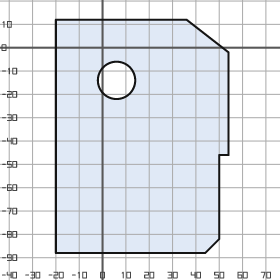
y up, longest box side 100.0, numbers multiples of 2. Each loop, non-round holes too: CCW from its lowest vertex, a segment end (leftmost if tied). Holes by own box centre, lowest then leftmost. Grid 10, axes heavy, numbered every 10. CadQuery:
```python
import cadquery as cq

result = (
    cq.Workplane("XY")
    .moveTo(-20.0, -88.0)
    .lineTo(44.0, -88.0)
    .lineTo(50.0, -82.0)
    .lineTo(50.0, -46.0)
    .lineTo(54.0, -46.0)
    .lineTo(54.0, -2.0)
    .lineTo(36.0, 12.0)
    .lineTo(-20.0, 12.0)
    .close()
    .moveTo(6.0, -14.0)
    .circle(8.0)
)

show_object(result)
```